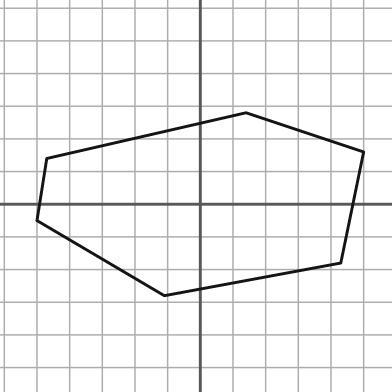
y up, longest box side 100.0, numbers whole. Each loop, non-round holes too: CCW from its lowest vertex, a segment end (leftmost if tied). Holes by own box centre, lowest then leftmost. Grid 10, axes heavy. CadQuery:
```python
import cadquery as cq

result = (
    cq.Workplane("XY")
    .moveTo(-11.0, -28.0)
    .lineTo(43.0, -18.0)
    .lineTo(50.0, 16.0)
    .lineTo(14.0, 28.0)
    .lineTo(-47.0, 14.0)
    .lineTo(-50.0, -5.0)
    .close()
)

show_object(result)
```